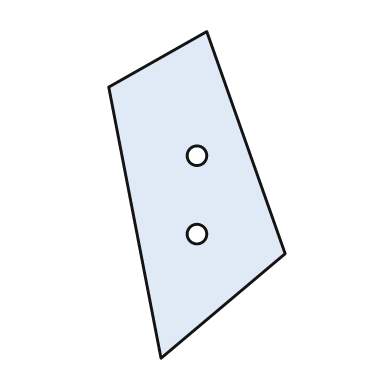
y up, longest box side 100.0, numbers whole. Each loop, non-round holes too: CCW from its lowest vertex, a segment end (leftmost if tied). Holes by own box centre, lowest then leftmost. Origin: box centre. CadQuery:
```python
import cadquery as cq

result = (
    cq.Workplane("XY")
    .moveTo(-11.0, -50.0)
    .lineTo(27.0, -18.0)
    .lineTo(3.0, 50.0)
    .lineTo(-27.0, 33.0)
    .close()
    .moveTo(0.0, -12.0)
    .circle(3.0)
    .moveTo(0.0, 12.0)
    .circle(3.0)
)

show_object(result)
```